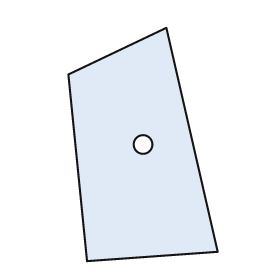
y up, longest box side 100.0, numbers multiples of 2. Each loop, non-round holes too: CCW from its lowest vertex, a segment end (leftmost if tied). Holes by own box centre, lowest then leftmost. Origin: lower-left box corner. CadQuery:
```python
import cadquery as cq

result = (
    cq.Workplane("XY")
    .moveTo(8.0, 0.0)
    .lineTo(64.0, 4.0)
    .lineTo(42.0, 100.0)
    .lineTo(0.0, 80.0)
    .close()
    .moveTo(32.0, 50.0)
    .circle(4.0)
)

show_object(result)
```